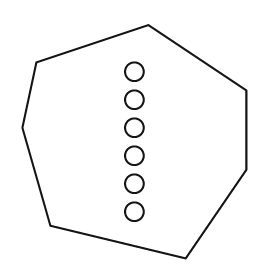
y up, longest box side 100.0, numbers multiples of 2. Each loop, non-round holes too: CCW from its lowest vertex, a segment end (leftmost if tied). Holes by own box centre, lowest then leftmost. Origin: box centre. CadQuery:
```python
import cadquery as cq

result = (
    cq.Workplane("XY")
    .moveTo(22.0, -50.0)
    .lineTo(48.0, -12.0)
    .lineTo(48.0, 22.0)
    .lineTo(6.0, 50.0)
    .lineTo(-42.0, 34.0)
    .lineTo(-48.0, 6.0)
    .lineTo(-36.0, -36.0)
    .close()
    .moveTo(0.0, -30.0)
    .circle(4.0)
    .moveTo(0.0, -18.0)
    .circle(4.0)
    .moveTo(0.0, -6.0)
    .circle(4.0)
    .moveTo(0.0, 6.0)
    .circle(4.0)
    .moveTo(0.0, 18.0)
    .circle(4.0)
    .moveTo(0.0, 30.0)
    .circle(4.0)
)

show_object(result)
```